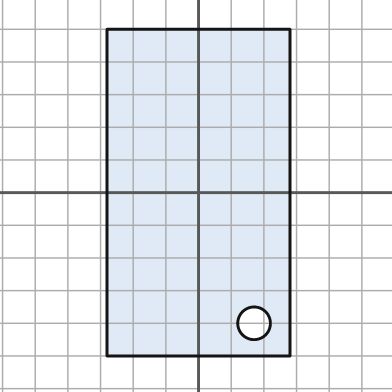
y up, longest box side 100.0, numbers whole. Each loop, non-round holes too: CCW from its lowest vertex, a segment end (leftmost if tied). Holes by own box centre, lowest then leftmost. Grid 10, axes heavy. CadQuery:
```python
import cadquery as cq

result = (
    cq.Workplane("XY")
    .moveTo(-28.0, -50.0)
    .lineTo(28.0, -50.0)
    .lineTo(28.0, 50.0)
    .lineTo(-28.0, 50.0)
    .close()
    .moveTo(17.0, -40.0)
    .circle(5.0)
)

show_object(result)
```